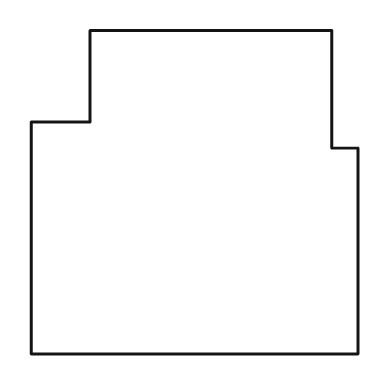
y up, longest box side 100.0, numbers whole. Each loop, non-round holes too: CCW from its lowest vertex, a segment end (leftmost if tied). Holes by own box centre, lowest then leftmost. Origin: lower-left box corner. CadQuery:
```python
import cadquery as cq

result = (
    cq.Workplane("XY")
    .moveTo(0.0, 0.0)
    .lineTo(100.0, 0.0)
    .lineTo(100.0, 63.0)
    .lineTo(92.0, 63.0)
    .lineTo(92.0, 99.0)
    .lineTo(18.0, 99.0)
    .lineTo(18.0, 71.0)
    .lineTo(0.0, 71.0)
    .close()
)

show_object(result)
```